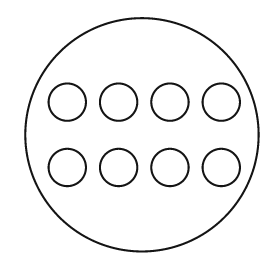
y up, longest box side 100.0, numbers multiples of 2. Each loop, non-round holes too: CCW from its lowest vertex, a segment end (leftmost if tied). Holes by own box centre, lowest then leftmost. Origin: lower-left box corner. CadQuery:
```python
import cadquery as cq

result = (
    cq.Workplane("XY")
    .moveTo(50.0, 50.0)
    .circle(50.0)
    .moveTo(18.0, 36.0)
    .circle(8.0)
    .moveTo(40.0, 36.0)
    .circle(8.0)
    .moveTo(62.0, 36.0)
    .circle(8.0)
    .moveTo(84.0, 36.0)
    .circle(8.0)
    .moveTo(18.0, 64.0)
    .circle(8.0)
    .moveTo(40.0, 64.0)
    .circle(8.0)
    .moveTo(62.0, 64.0)
    .circle(8.0)
    .moveTo(84.0, 64.0)
    .circle(8.0)
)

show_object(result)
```